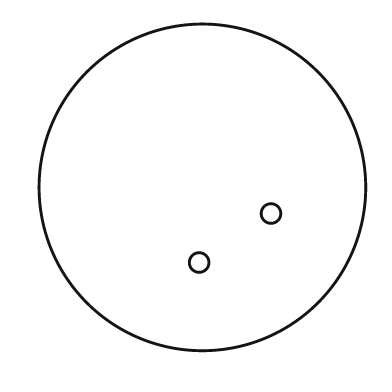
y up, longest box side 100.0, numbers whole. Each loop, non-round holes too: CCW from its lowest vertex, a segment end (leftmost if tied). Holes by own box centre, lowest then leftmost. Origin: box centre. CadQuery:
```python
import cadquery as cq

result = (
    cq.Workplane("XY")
    .moveTo(0.0, 0.0)
    .circle(50.0)
    .moveTo(-1.0, -23.0)
    .circle(3.0)
    .moveTo(21.0, -8.0)
    .circle(3.0)
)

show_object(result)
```